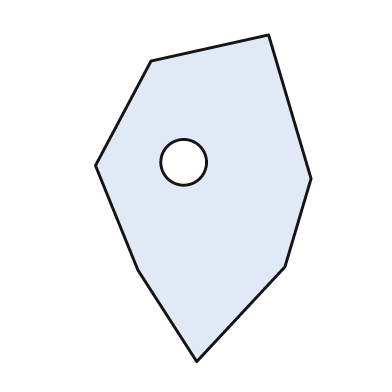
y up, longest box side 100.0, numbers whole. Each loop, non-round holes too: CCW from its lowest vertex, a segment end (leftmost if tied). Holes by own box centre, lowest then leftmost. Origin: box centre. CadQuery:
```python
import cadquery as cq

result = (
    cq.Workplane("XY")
    .moveTo(-2.0, -50.0)
    .lineTo(25.0, -21.0)
    .lineTo(33.0, 6.0)
    .lineTo(20.0, 50.0)
    .lineTo(-16.0, 42.0)
    .lineTo(-33.0, 10.0)
    .lineTo(-20.0, -22.0)
    .close()
    .moveTo(-6.0, 11.0)
    .circle(7.0)
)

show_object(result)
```